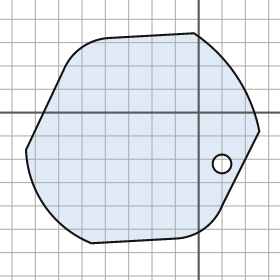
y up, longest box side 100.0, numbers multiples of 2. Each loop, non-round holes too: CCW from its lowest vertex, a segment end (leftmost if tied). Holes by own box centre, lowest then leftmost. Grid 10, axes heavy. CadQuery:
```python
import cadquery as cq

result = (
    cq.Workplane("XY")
    .moveTo(-46.0, -56.0)
    .lineTo(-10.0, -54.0)
    .threePointArc((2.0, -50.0), (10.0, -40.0))
    .lineTo(26.0, -8.0)
    .threePointArc((16.0, 16.0), (-2.0, 34.0))
    .lineTo(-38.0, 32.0)
    .threePointArc((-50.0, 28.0), (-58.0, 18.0))
    .lineTo(-74.0, -16.0)
    .threePointArc((-66.0, -40.0), (-46.0, -56.0))
    .close()
    .moveTo(10.0, -22.0)
    .circle(4.0)
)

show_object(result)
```